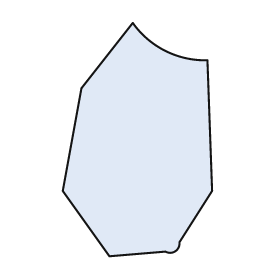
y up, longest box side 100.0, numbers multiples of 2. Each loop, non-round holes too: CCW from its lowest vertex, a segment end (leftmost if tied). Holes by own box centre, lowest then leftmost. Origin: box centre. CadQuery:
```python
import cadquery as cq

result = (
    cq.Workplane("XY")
    .moveTo(-12.0, -50.0)
    .lineTo(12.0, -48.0)
    .threePointArc((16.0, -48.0), (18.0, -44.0))
    .lineTo(32.0, -22.0)
    .lineTo(30.0, 34.0)
    .threePointArc((12.0, 38.0), (-2.0, 50.0))
    .lineTo(-24.0, 22.0)
    .lineTo(-32.0, -22.0)
    .close()
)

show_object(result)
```